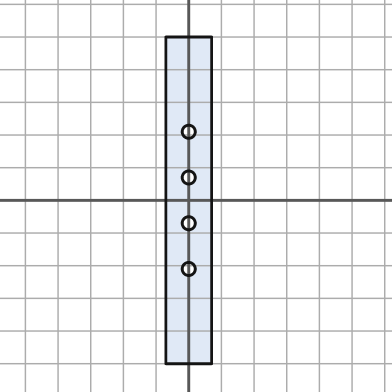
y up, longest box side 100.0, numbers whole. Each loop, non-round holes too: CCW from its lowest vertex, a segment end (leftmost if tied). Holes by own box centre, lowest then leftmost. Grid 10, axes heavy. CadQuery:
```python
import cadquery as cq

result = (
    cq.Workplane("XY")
    .moveTo(-7.0, -50.0)
    .lineTo(7.0, -50.0)
    .lineTo(7.0, 50.0)
    .lineTo(-7.0, 50.0)
    .close()
    .moveTo(0.0, -21.0)
    .circle(2.0)
    .moveTo(0.0, -7.0)
    .circle(2.0)
    .moveTo(0.0, 7.0)
    .circle(2.0)
    .moveTo(0.0, 21.0)
    .circle(2.0)
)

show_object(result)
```